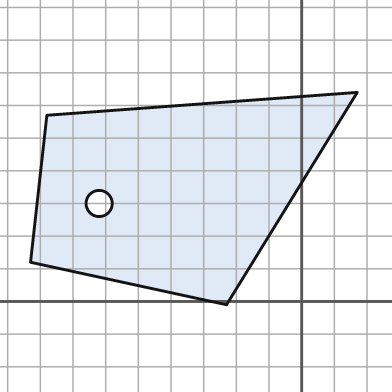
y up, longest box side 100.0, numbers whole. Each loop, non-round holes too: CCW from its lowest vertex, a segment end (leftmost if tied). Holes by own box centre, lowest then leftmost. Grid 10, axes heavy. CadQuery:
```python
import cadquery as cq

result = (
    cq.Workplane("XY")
    .moveTo(-23.0, -1.0)
    .lineTo(17.0, 64.0)
    .lineTo(-78.0, 57.0)
    .lineTo(-83.0, 12.0)
    .close()
    .moveTo(-62.0, 30.0)
    .circle(4.0)
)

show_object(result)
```